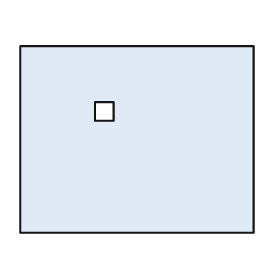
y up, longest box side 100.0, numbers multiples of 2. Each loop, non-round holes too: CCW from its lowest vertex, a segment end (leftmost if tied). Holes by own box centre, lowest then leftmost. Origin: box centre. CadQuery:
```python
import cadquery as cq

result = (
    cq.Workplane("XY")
    .moveTo(-50.0, -40.0)
    .lineTo(50.0, -40.0)
    .lineTo(50.0, 40.0)
    .lineTo(-50.0, 40.0)
    .close()
    .moveTo(-18.0, 8.0)
    .lineTo(-10.0, 8.0)
    .lineTo(-10.0, 16.0)
    .lineTo(-18.0, 16.0)
    .close()
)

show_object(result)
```